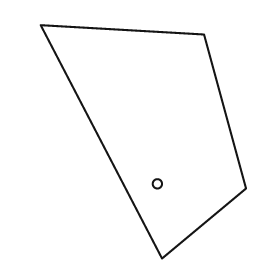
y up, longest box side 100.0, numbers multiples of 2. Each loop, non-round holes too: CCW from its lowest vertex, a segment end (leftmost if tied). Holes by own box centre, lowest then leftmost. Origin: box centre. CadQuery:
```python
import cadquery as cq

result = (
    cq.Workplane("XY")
    .moveTo(8.0, -50.0)
    .lineTo(44.0, -20.0)
    .lineTo(26.0, 46.0)
    .lineTo(-44.0, 50.0)
    .close()
    .moveTo(6.0, -18.0)
    .circle(2.0)
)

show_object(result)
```